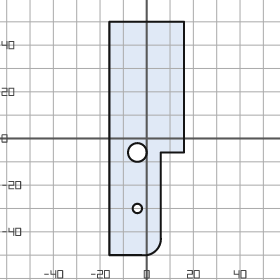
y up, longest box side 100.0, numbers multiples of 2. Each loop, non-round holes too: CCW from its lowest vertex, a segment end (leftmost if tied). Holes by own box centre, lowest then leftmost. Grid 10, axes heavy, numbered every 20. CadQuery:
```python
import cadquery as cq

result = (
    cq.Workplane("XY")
    .moveTo(-16.0, -50.0)
    .lineTo(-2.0, -50.0)
    .threePointArc((4.0, -48.0), (6.0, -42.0))
    .lineTo(6.0, -6.0)
    .lineTo(16.0, -6.0)
    .lineTo(16.0, 50.0)
    .lineTo(-16.0, 50.0)
    .close()
    .moveTo(-4.0, -30.0)
    .circle(2.0)
    .moveTo(-4.0, -6.0)
    .circle(4.0)
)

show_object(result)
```